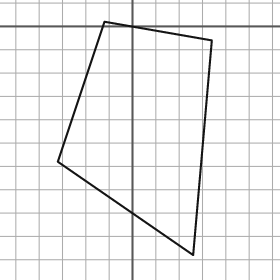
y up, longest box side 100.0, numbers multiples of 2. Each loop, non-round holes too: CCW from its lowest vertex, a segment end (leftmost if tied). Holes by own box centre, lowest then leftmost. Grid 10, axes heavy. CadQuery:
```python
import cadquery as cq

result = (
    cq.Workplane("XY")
    .moveTo(26.0, -98.0)
    .lineTo(34.0, -6.0)
    .lineTo(-12.0, 2.0)
    .lineTo(-32.0, -58.0)
    .close()
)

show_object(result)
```